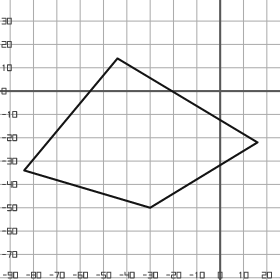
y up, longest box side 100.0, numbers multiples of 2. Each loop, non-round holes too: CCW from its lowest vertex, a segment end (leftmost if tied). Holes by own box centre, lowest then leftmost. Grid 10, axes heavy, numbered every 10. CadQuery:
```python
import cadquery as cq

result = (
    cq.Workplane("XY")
    .moveTo(-30.0, -50.0)
    .lineTo(16.0, -22.0)
    .lineTo(-44.0, 14.0)
    .lineTo(-84.0, -34.0)
    .close()
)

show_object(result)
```